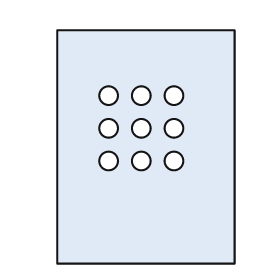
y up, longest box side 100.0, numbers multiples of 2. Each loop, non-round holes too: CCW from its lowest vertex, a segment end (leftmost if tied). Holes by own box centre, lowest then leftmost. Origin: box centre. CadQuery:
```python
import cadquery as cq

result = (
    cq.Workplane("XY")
    .moveTo(-38.0, -50.0)
    .lineTo(38.0, -50.0)
    .lineTo(38.0, 50.0)
    .lineTo(-38.0, 50.0)
    .close()
    .moveTo(-16.0, -6.0)
    .circle(4.0)
    .moveTo(-2.0, -6.0)
    .circle(4.0)
    .moveTo(12.0, -6.0)
    .circle(4.0)
    .moveTo(-16.0, 8.0)
    .circle(4.0)
    .moveTo(-2.0, 8.0)
    .circle(4.0)
    .moveTo(12.0, 8.0)
    .circle(4.0)
    .moveTo(-16.0, 22.0)
    .circle(4.0)
    .moveTo(-2.0, 22.0)
    .circle(4.0)
    .moveTo(12.0, 22.0)
    .circle(4.0)
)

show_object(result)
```